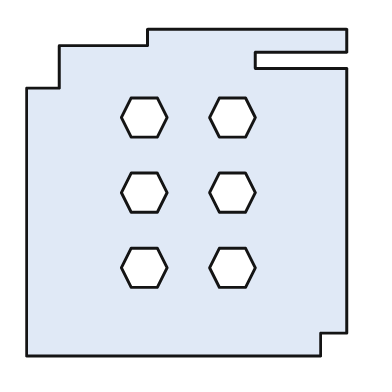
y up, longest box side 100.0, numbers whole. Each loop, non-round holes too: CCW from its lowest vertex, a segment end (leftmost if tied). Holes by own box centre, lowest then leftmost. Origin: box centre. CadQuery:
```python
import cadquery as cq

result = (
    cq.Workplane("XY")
    .moveTo(-49.0, -50.0)
    .lineTo(41.0, -50.0)
    .lineTo(41.0, -43.0)
    .lineTo(49.0, -43.0)
    .lineTo(49.0, 38.0)
    .lineTo(21.0, 38.0)
    .lineTo(21.0, 43.0)
    .lineTo(49.0, 43.0)
    .lineTo(49.0, 50.0)
    .lineTo(-12.0, 50.0)
    .lineTo(-12.0, 45.0)
    .lineTo(-39.0, 45.0)
    .lineTo(-39.0, 32.0)
    .lineTo(-49.0, 32.0)
    .close()
    .moveTo(-17.0, -29.0)
    .lineTo(-9.0, -29.0)
    .lineTo(-6.0, -23.0)
    .lineTo(-9.0, -17.0)
    .lineTo(-17.0, -17.0)
    .lineTo(-20.0, -23.0)
    .close()
    .moveTo(10.0, -29.0)
    .lineTo(18.0, -29.0)
    .lineTo(21.0, -23.0)
    .lineTo(18.0, -17.0)
    .lineTo(10.0, -17.0)
    .lineTo(7.0, -23.0)
    .close()
    .moveTo(-17.0, -6.0)
    .lineTo(-9.0, -6.0)
    .lineTo(-6.0, 0.0)
    .lineTo(-9.0, 6.0)
    .lineTo(-17.0, 6.0)
    .lineTo(-20.0, 0.0)
    .close()
    .moveTo(10.0, -6.0)
    .lineTo(18.0, -6.0)
    .lineTo(21.0, 0.0)
    .lineTo(18.0, 6.0)
    .lineTo(10.0, 6.0)
    .lineTo(7.0, 0.0)
    .close()
    .moveTo(-17.0, 17.0)
    .lineTo(-9.0, 17.0)
    .lineTo(-6.0, 23.0)
    .lineTo(-9.0, 29.0)
    .lineTo(-17.0, 29.0)
    .lineTo(-20.0, 23.0)
    .close()
    .moveTo(10.0, 17.0)
    .lineTo(18.0, 17.0)
    .lineTo(21.0, 23.0)
    .lineTo(18.0, 29.0)
    .lineTo(10.0, 29.0)
    .lineTo(7.0, 23.0)
    .close()
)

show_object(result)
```